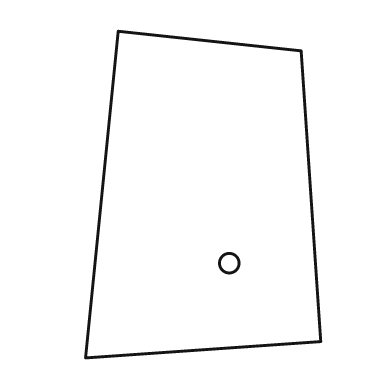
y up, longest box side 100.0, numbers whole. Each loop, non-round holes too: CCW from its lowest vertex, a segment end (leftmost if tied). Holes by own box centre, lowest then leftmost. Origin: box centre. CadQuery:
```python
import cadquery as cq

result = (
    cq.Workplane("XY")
    .moveTo(-36.0, -50.0)
    .lineTo(36.0, -45.0)
    .lineTo(30.0, 44.0)
    .lineTo(-26.0, 50.0)
    .close()
    .moveTo(8.0, -21.0)
    .circle(3.0)
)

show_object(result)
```